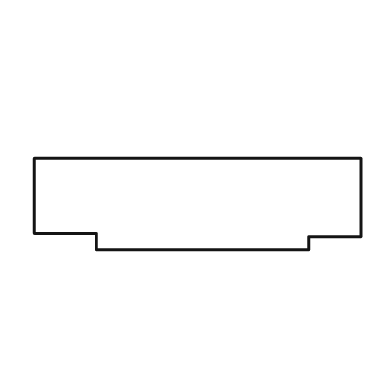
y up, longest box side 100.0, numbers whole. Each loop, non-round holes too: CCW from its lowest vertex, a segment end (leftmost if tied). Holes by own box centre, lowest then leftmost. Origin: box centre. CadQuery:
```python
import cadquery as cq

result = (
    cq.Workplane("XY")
    .moveTo(-31.0, -14.0)
    .lineTo(34.0, -14.0)
    .lineTo(34.0, -10.0)
    .lineTo(50.0, -10.0)
    .lineTo(50.0, 14.0)
    .lineTo(-50.0, 14.0)
    .lineTo(-50.0, -9.0)
    .lineTo(-31.0, -9.0)
    .close()
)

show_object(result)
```